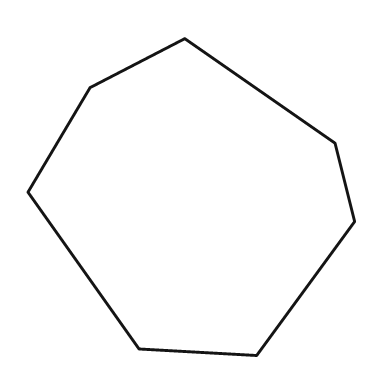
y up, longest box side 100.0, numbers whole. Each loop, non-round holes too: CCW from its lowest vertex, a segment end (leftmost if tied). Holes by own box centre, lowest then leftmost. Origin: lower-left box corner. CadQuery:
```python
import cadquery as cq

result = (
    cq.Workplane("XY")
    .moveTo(70.0, 0.0)
    .lineTo(100.0, 41.0)
    .lineTo(94.0, 65.0)
    .lineTo(48.0, 97.0)
    .lineTo(19.0, 82.0)
    .lineTo(0.0, 50.0)
    .lineTo(34.0, 2.0)
    .close()
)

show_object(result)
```